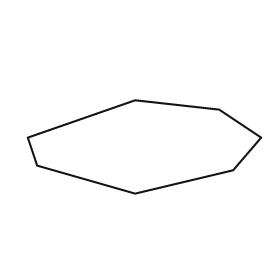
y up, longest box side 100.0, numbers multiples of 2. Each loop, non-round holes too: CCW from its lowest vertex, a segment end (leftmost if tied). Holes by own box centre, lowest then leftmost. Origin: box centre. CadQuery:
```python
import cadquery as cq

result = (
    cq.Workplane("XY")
    .moveTo(-4.0, -20.0)
    .lineTo(38.0, -10.0)
    .lineTo(50.0, 4.0)
    .lineTo(32.0, 16.0)
    .lineTo(-4.0, 20.0)
    .lineTo(-50.0, 4.0)
    .lineTo(-46.0, -8.0)
    .close()
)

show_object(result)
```